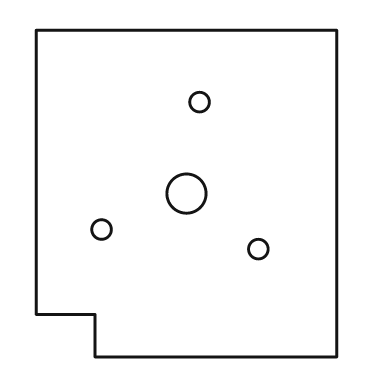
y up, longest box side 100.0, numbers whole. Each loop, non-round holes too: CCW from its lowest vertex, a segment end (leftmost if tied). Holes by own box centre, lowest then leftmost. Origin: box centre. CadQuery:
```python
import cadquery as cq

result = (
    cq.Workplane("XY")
    .moveTo(-28.0, -50.0)
    .lineTo(46.0, -50.0)
    .lineTo(46.0, 50.0)
    .lineTo(-46.0, 50.0)
    .lineTo(-46.0, -37.0)
    .lineTo(-28.0, -37.0)
    .close()
    .moveTo(22.0, -17.0)
    .circle(3.0)
    .moveTo(-26.0, -11.0)
    .circle(3.0)
    .moveTo(0.0, 0.0)
    .circle(6.0)
    .moveTo(4.0, 28.0)
    .circle(3.0)
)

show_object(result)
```